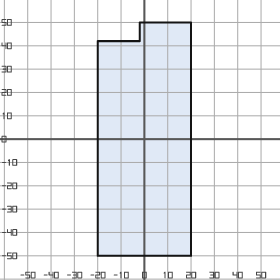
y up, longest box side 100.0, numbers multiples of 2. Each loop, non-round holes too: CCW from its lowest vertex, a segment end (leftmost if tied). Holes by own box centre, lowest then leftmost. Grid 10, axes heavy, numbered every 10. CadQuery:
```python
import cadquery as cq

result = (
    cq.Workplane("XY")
    .moveTo(-20.0, -50.0)
    .lineTo(20.0, -50.0)
    .lineTo(20.0, 50.0)
    .lineTo(-2.0, 50.0)
    .lineTo(-2.0, 42.0)
    .lineTo(-20.0, 42.0)
    .close()
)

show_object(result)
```